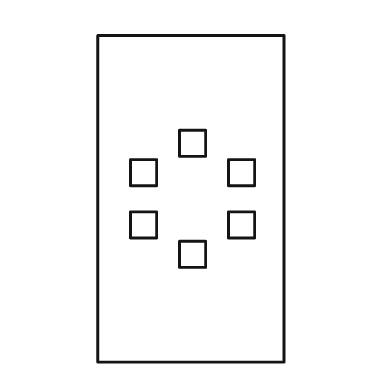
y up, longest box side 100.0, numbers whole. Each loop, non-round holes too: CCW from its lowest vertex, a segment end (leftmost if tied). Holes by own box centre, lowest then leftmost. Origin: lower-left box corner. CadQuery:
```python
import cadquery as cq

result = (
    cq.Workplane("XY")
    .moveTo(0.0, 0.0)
    .lineTo(57.0, 0.0)
    .lineTo(57.0, 100.0)
    .lineTo(0.0, 100.0)
    .close()
    .moveTo(25.0, 29.0)
    .lineTo(33.0, 29.0)
    .lineTo(33.0, 37.0)
    .lineTo(25.0, 37.0)
    .close()
    .moveTo(10.0, 38.0)
    .lineTo(18.0, 38.0)
    .lineTo(18.0, 46.0)
    .lineTo(10.0, 46.0)
    .close()
    .moveTo(40.0, 38.0)
    .lineTo(48.0, 38.0)
    .lineTo(48.0, 46.0)
    .lineTo(40.0, 46.0)
    .close()
    .moveTo(10.0, 54.0)
    .lineTo(18.0, 54.0)
    .lineTo(18.0, 62.0)
    .lineTo(10.0, 62.0)
    .close()
    .moveTo(40.0, 54.0)
    .lineTo(48.0, 54.0)
    .lineTo(48.0, 62.0)
    .lineTo(40.0, 62.0)
    .close()
    .moveTo(25.0, 63.0)
    .lineTo(33.0, 63.0)
    .lineTo(33.0, 71.0)
    .lineTo(25.0, 71.0)
    .close()
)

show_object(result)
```